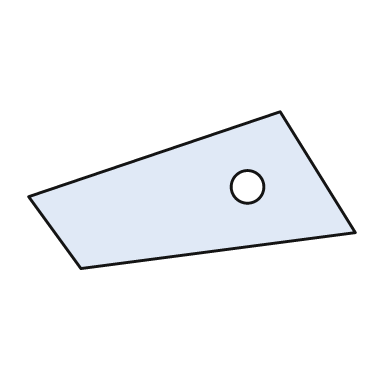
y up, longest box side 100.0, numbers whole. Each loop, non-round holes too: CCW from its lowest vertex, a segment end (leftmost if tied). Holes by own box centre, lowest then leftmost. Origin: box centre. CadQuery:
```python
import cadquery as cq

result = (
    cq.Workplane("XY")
    .moveTo(-34.0, -24.0)
    .lineTo(50.0, -13.0)
    .lineTo(27.0, 24.0)
    .lineTo(-50.0, -2.0)
    .close()
    .moveTo(17.0, 1.0)
    .circle(5.0)
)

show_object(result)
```